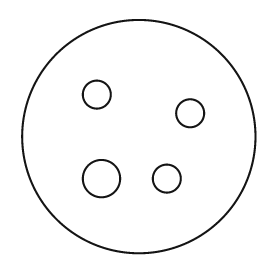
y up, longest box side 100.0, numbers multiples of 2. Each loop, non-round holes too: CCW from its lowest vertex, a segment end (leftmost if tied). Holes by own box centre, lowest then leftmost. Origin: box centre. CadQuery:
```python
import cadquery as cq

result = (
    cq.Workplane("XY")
    .moveTo(0.0, 0.0)
    .circle(50.0)
    .moveTo(-16.0, -18.0)
    .circle(8.0)
    .moveTo(12.0, -18.0)
    .circle(6.0)
    .moveTo(22.0, 10.0)
    .circle(6.0)
    .moveTo(-18.0, 18.0)
    .circle(6.0)
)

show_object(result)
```